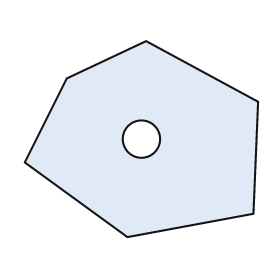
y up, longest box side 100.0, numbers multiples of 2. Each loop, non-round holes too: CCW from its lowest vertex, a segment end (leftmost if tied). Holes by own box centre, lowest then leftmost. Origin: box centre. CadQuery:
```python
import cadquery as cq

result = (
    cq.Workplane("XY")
    .moveTo(-6.0, -42.0)
    .lineTo(48.0, -32.0)
    .lineTo(50.0, 16.0)
    .lineTo(2.0, 42.0)
    .lineTo(-32.0, 26.0)
    .lineTo(-50.0, -10.0)
    .close()
    .moveTo(0.0, 0.0)
    .circle(8.0)
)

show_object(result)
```